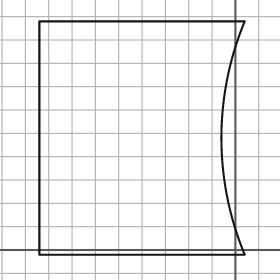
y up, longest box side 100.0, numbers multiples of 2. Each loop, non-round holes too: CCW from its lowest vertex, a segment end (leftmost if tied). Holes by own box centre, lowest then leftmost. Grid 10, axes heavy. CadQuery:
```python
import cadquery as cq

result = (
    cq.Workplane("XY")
    .moveTo(-84.0, -2.0)
    .lineTo(4.0, -2.0)
    .threePointArc((-6.0, 48.0), (4.0, 98.0))
    .lineTo(-84.0, 98.0)
    .close()
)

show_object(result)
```